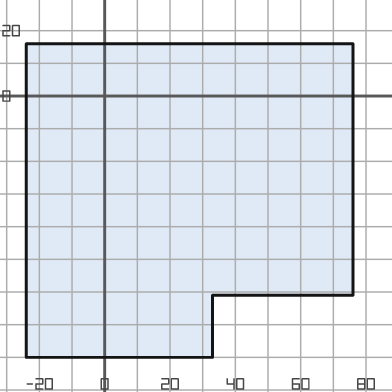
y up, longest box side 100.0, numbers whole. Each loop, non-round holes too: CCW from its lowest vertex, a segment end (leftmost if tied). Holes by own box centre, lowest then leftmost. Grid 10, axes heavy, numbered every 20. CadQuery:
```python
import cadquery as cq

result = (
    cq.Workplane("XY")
    .moveTo(-24.0, -80.0)
    .lineTo(33.0, -80.0)
    .lineTo(33.0, -61.0)
    .lineTo(76.0, -61.0)
    .lineTo(76.0, 16.0)
    .lineTo(-24.0, 16.0)
    .close()
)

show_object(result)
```